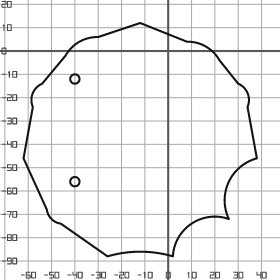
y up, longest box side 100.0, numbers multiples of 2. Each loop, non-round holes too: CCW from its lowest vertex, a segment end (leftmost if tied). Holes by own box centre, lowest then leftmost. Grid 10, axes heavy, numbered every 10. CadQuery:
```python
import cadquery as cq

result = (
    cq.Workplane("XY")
    .moveTo(-26.0, -88.0)
    .threePointArc((-12.0, -86.0), (2.0, -88.0))
    .threePointArc((10.0, -74.0), (26.0, -72.0))
    .threePointArc((26.0, -56.0), (38.0, -46.0))
    .lineTo(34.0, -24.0)
    .threePointArc((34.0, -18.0), (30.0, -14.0))
    .lineTo(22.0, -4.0)
    .threePointArc((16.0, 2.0), (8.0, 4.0))
    .lineTo(-12.0, 12.0)
    .lineTo(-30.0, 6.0)
    .threePointArc((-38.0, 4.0), (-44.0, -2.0))
    .lineTo(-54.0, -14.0)
    .threePointArc((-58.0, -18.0), (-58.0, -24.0))
    .lineTo(-62.0, -46.0)
    .lineTo(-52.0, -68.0)
    .threePointArc((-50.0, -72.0), (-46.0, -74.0))
    .close()
    .moveTo(-40.0, -56.0)
    .circle(2.0)
    .moveTo(-40.0, -12.0)
    .circle(2.0)
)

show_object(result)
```